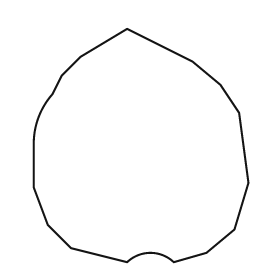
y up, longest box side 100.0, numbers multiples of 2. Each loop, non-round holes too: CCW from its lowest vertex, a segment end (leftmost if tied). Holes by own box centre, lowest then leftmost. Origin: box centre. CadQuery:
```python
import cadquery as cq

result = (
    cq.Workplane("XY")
    .moveTo(-6.0, -50.0)
    .threePointArc((4.0, -46.0), (14.0, -50.0))
    .lineTo(28.0, -46.0)
    .lineTo(40.0, -36.0)
    .lineTo(46.0, -16.0)
    .lineTo(42.0, 14.0)
    .lineTo(34.0, 26.0)
    .lineTo(22.0, 36.0)
    .lineTo(-6.0, 50.0)
    .lineTo(-26.0, 38.0)
    .lineTo(-34.0, 30.0)
    .lineTo(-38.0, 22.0)
    .threePointArc((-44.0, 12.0), (-46.0, 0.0))
    .lineTo(-46.0, -18.0)
    .lineTo(-40.0, -34.0)
    .lineTo(-30.0, -44.0)
    .close()
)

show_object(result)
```